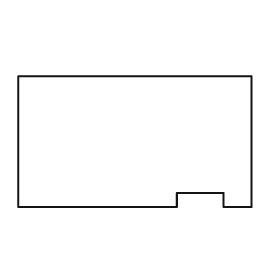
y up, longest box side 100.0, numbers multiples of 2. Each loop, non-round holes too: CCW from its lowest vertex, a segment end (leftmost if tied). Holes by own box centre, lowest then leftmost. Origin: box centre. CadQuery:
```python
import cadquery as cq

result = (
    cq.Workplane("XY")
    .moveTo(-50.0, -28.0)
    .lineTo(18.0, -28.0)
    .lineTo(18.0, -22.0)
    .lineTo(38.0, -22.0)
    .lineTo(38.0, -28.0)
    .lineTo(50.0, -28.0)
    .lineTo(50.0, 28.0)
    .lineTo(-50.0, 28.0)
    .close()
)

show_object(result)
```